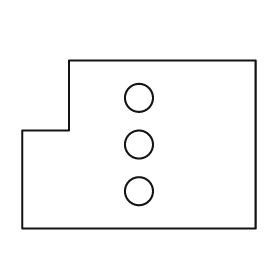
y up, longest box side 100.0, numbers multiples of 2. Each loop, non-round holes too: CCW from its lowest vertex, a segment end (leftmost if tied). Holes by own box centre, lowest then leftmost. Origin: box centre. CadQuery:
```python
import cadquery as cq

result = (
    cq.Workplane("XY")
    .moveTo(-50.0, -36.0)
    .lineTo(50.0, -36.0)
    .lineTo(50.0, 36.0)
    .lineTo(-30.0, 36.0)
    .lineTo(-30.0, 6.0)
    .lineTo(-50.0, 6.0)
    .close()
    .moveTo(0.0, -20.0)
    .circle(6.0)
    .moveTo(0.0, 0.0)
    .circle(6.0)
    .moveTo(0.0, 20.0)
    .circle(6.0)
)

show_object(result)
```